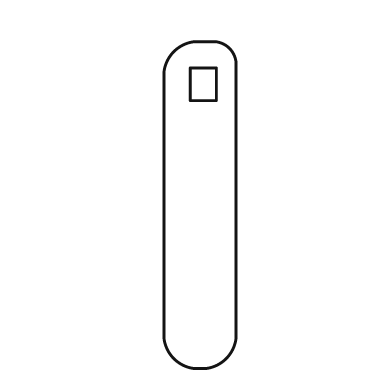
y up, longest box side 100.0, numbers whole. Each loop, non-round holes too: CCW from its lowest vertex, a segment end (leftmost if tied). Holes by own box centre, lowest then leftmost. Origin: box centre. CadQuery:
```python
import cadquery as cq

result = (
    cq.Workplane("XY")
    .moveTo(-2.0, -50.0)
    .lineTo(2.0, -50.0)
    .threePointArc((8.0, -47.0), (11.0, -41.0))
    .lineTo(11.0, 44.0)
    .threePointArc((9.0, 48.0), (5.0, 50.0))
    .lineTo(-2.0, 50.0)
    .threePointArc((-8.0, 47.0), (-11.0, 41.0))
    .lineTo(-11.0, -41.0)
    .threePointArc((-8.0, -47.0), (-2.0, -50.0))
    .close()
    .moveTo(-3.0, 32.0)
    .lineTo(5.0, 32.0)
    .lineTo(5.0, 42.0)
    .lineTo(-3.0, 42.0)
    .close()
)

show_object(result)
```